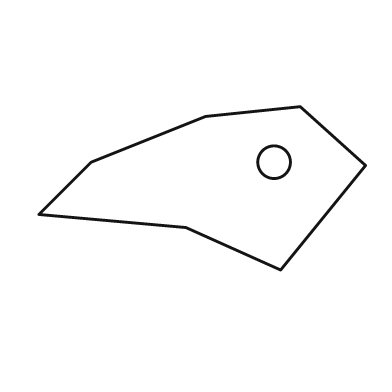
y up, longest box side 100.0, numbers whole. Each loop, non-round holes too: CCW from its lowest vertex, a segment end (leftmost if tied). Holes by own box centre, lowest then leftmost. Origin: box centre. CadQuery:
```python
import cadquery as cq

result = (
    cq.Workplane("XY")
    .moveTo(24.0, -25.0)
    .lineTo(50.0, 7.0)
    .lineTo(30.0, 25.0)
    .lineTo(1.0, 22.0)
    .lineTo(-34.0, 8.0)
    .lineTo(-50.0, -8.0)
    .lineTo(-5.0, -12.0)
    .close()
    .moveTo(22.0, 8.0)
    .circle(5.0)
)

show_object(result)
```